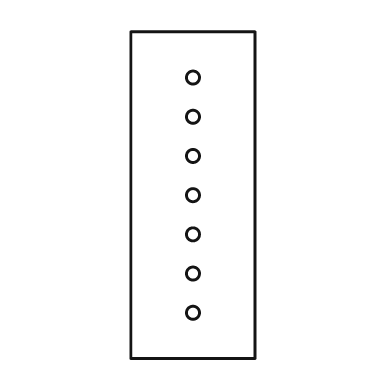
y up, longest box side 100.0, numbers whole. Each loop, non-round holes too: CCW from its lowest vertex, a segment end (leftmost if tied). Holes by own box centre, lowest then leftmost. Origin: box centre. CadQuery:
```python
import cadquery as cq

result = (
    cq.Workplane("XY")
    .moveTo(-19.0, -50.0)
    .lineTo(19.0, -50.0)
    .lineTo(19.0, 50.0)
    .lineTo(-19.0, 50.0)
    .close()
    .moveTo(0.0, -36.0)
    .circle(2.0)
    .moveTo(0.0, -24.0)
    .circle(2.0)
    .moveTo(0.0, -12.0)
    .circle(2.0)
    .moveTo(0.0, 0.0)
    .circle(2.0)
    .moveTo(0.0, 12.0)
    .circle(2.0)
    .moveTo(0.0, 24.0)
    .circle(2.0)
    .moveTo(0.0, 36.0)
    .circle(2.0)
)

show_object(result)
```